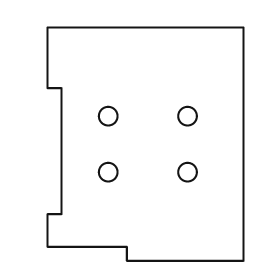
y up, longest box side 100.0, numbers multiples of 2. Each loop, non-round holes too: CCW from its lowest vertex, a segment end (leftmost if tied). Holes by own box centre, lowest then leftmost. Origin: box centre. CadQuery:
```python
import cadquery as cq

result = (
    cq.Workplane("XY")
    .moveTo(-8.0, -50.0)
    .lineTo(42.0, -50.0)
    .lineTo(42.0, 50.0)
    .lineTo(-42.0, 50.0)
    .lineTo(-42.0, 24.0)
    .lineTo(-36.0, 24.0)
    .lineTo(-36.0, -30.0)
    .lineTo(-42.0, -30.0)
    .lineTo(-42.0, -44.0)
    .lineTo(-8.0, -44.0)
    .close()
    .moveTo(-16.0, -12.0)
    .circle(4.0)
    .moveTo(18.0, -12.0)
    .circle(4.0)
    .moveTo(-16.0, 12.0)
    .circle(4.0)
    .moveTo(18.0, 12.0)
    .circle(4.0)
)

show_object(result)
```